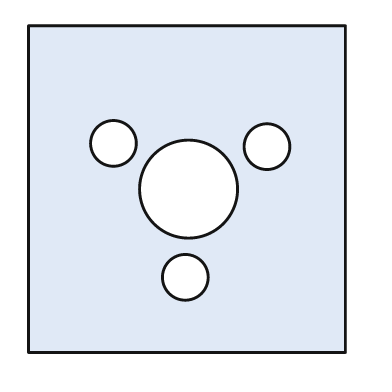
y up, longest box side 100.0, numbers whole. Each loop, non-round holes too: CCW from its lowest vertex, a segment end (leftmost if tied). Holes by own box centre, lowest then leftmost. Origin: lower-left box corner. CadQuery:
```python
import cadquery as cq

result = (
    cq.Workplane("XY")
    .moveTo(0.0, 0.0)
    .lineTo(97.0, 0.0)
    .lineTo(97.0, 100.0)
    .lineTo(0.0, 100.0)
    .close()
    .moveTo(48.0, 23.0)
    .circle(7.0)
    .moveTo(49.0, 50.0)
    .circle(15.0)
    .moveTo(73.0, 63.0)
    .circle(7.0)
    .moveTo(26.0, 64.0)
    .circle(7.0)
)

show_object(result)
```